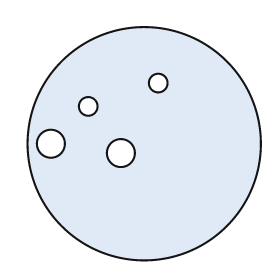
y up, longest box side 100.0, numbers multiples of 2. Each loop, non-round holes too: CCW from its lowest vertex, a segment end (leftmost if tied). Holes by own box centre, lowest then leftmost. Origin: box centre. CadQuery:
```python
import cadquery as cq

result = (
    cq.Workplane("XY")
    .moveTo(0.0, 0.0)
    .circle(50.0)
    .moveTo(-10.0, -4.0)
    .circle(6.0)
    .moveTo(-40.0, 0.0)
    .circle(6.0)
    .moveTo(-24.0, 16.0)
    .circle(4.0)
    .moveTo(6.0, 26.0)
    .circle(4.0)
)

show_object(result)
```